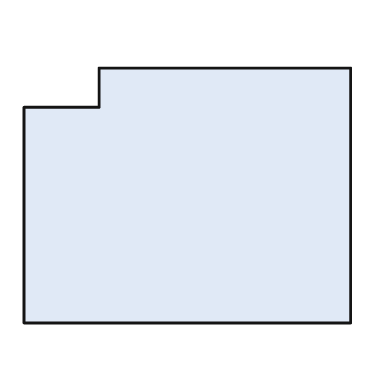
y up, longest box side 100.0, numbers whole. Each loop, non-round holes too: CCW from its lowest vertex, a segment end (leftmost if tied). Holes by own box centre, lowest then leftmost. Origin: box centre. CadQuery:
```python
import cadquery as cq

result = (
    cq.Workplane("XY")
    .moveTo(-50.0, -39.0)
    .lineTo(50.0, -39.0)
    .lineTo(50.0, 39.0)
    .lineTo(-27.0, 39.0)
    .lineTo(-27.0, 27.0)
    .lineTo(-50.0, 27.0)
    .close()
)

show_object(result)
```